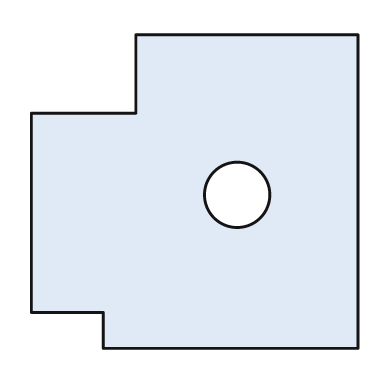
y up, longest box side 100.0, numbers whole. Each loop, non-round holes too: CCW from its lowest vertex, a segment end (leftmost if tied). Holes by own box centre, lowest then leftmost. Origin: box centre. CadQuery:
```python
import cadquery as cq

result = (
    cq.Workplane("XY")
    .moveTo(-28.0, -48.0)
    .lineTo(50.0, -48.0)
    .lineTo(50.0, 48.0)
    .lineTo(-18.0, 48.0)
    .lineTo(-18.0, 24.0)
    .lineTo(-50.0, 24.0)
    .lineTo(-50.0, -37.0)
    .lineTo(-28.0, -37.0)
    .close()
    .moveTo(13.0, -1.0)
    .circle(10.0)
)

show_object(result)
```